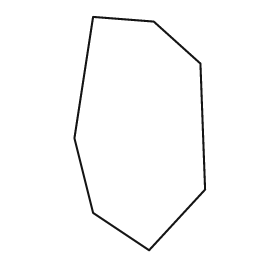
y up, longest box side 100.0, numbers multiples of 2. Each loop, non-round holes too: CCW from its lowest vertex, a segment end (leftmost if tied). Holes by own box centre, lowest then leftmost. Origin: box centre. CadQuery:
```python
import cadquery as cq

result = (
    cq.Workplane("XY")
    .moveTo(4.0, -50.0)
    .lineTo(28.0, -24.0)
    .lineTo(26.0, 30.0)
    .lineTo(6.0, 48.0)
    .lineTo(-20.0, 50.0)
    .lineTo(-28.0, -2.0)
    .lineTo(-20.0, -34.0)
    .close()
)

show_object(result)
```